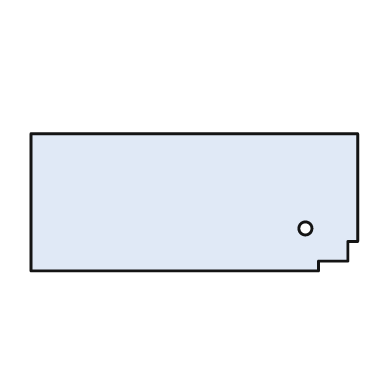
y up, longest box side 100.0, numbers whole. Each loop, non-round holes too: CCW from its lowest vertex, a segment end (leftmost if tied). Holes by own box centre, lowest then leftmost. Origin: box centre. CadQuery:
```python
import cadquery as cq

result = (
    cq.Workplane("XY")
    .moveTo(-50.0, -21.0)
    .lineTo(38.0, -21.0)
    .lineTo(38.0, -18.0)
    .lineTo(47.0, -18.0)
    .lineTo(47.0, -12.0)
    .lineTo(50.0, -12.0)
    .lineTo(50.0, 21.0)
    .lineTo(-50.0, 21.0)
    .close()
    .moveTo(34.0, -8.0)
    .circle(2.0)
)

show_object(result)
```